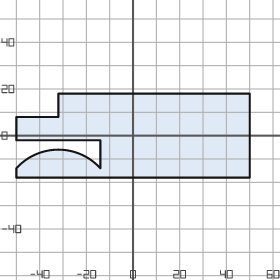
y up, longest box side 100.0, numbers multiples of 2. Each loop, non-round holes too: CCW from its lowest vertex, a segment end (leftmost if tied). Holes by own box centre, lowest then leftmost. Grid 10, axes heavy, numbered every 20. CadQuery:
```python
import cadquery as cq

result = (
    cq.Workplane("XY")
    .moveTo(-50.0, -18.0)
    .lineTo(50.0, -18.0)
    .lineTo(50.0, 18.0)
    .lineTo(-32.0, 18.0)
    .lineTo(-32.0, 8.0)
    .lineTo(-50.0, 8.0)
    .lineTo(-50.0, -2.0)
    .lineTo(-14.0, -2.0)
    .lineTo(-14.0, -14.0)
    .threePointArc((-32.0, -6.0), (-50.0, -14.0))
    .close()
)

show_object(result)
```